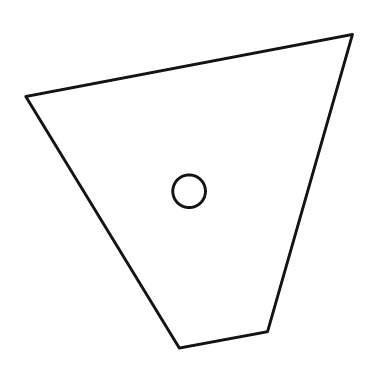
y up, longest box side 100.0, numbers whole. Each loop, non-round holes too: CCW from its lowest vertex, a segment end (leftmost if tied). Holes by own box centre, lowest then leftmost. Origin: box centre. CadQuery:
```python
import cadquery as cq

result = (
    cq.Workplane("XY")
    .moveTo(-3.0, -48.0)
    .lineTo(24.0, -43.0)
    .lineTo(50.0, 48.0)
    .lineTo(-50.0, 29.0)
    .close()
    .moveTo(0.0, 0.0)
    .circle(5.0)
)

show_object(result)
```